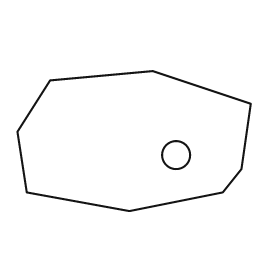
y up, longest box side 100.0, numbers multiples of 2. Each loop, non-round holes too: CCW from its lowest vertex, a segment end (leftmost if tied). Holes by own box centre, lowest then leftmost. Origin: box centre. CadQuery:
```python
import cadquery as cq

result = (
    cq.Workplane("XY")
    .moveTo(-2.0, -30.0)
    .lineTo(38.0, -22.0)
    .lineTo(46.0, -12.0)
    .lineTo(50.0, 16.0)
    .lineTo(8.0, 30.0)
    .lineTo(-36.0, 26.0)
    .lineTo(-50.0, 4.0)
    .lineTo(-46.0, -22.0)
    .close()
    .moveTo(18.0, -6.0)
    .circle(6.0)
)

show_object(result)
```